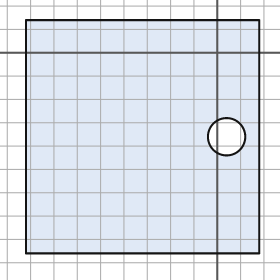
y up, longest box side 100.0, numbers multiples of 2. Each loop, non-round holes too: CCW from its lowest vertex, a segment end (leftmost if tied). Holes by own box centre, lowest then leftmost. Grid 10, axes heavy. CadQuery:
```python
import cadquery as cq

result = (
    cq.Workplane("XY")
    .moveTo(-82.0, -86.0)
    .lineTo(18.0, -86.0)
    .lineTo(18.0, 14.0)
    .lineTo(-82.0, 14.0)
    .close()
    .moveTo(4.0, -36.0)
    .circle(8.0)
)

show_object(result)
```